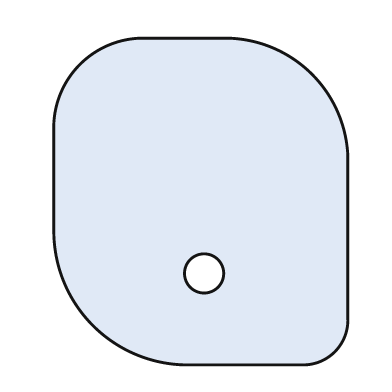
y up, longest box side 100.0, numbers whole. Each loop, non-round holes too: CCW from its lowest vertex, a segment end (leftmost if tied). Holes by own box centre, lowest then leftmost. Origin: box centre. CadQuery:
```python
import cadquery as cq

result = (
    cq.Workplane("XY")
    .moveTo(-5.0, -50.0)
    .lineTo(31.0, -50.0)
    .threePointArc((41.0, -46.0), (45.0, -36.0))
    .lineTo(45.0, 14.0)
    .threePointArc((34.0, 39.0), (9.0, 50.0))
    .lineTo(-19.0, 50.0)
    .threePointArc((-37.0, 42.0), (-45.0, 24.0))
    .lineTo(-45.0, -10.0)
    .threePointArc((-33.0, -38.0), (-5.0, -50.0))
    .close()
    .moveTo(1.0, -22.0)
    .circle(6.0)
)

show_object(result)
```